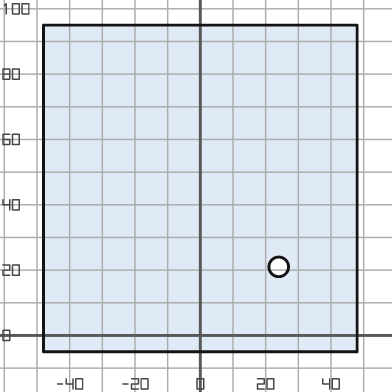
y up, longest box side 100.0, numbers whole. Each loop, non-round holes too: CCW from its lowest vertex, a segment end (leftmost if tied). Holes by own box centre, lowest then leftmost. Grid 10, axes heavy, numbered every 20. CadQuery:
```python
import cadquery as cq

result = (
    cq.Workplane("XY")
    .moveTo(-48.0, -5.0)
    .lineTo(48.0, -5.0)
    .lineTo(48.0, 95.0)
    .lineTo(-48.0, 95.0)
    .close()
    .moveTo(24.0, 21.0)
    .circle(3.0)
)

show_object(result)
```